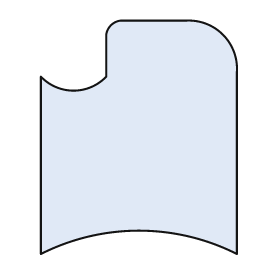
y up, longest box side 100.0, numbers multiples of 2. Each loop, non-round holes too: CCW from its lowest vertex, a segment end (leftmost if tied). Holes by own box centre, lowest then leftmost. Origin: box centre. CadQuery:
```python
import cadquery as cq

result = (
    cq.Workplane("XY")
    .moveTo(-42.0, -50.0)
    .threePointArc((0.0, -40.0), (42.0, -50.0))
    .lineTo(42.0, 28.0)
    .threePointArc((36.0, 44.0), (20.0, 50.0))
    .lineTo(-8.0, 50.0)
    .threePointArc((-12.0, 48.0), (-14.0, 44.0))
    .lineTo(-14.0, 26.0)
    .threePointArc((-28.0, 20.0), (-42.0, 26.0))
    .close()
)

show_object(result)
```